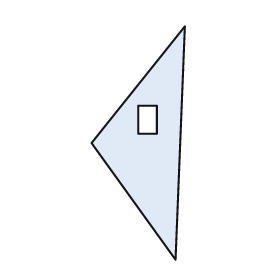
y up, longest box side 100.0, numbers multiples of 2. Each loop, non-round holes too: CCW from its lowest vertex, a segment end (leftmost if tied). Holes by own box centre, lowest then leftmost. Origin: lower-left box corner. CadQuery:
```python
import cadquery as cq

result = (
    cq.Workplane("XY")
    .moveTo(36.0, 0.0)
    .lineTo(40.0, 100.0)
    .lineTo(0.0, 50.0)
    .close()
    .moveTo(20.0, 54.0)
    .lineTo(28.0, 54.0)
    .lineTo(28.0, 66.0)
    .lineTo(20.0, 66.0)
    .close()
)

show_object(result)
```